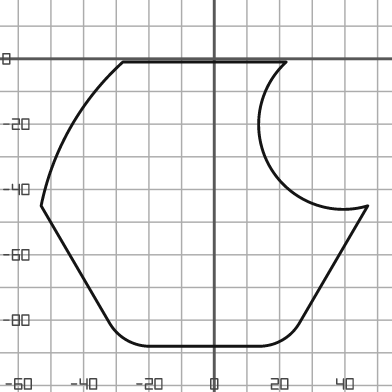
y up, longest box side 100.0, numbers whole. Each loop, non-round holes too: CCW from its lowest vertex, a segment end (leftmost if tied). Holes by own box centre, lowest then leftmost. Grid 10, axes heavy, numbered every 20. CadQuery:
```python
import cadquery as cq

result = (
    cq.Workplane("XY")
    .moveTo(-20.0, -88.0)
    .lineTo(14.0, -88.0)
    .threePointArc((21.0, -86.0), (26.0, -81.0))
    .lineTo(47.0, -45.0)
    .threePointArc((17.0, -33.0), (22.0, -1.0))
    .lineTo(-28.0, -1.0)
    .threePointArc((-44.0, -21.0), (-53.0, -45.0))
    .lineTo(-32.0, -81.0)
    .threePointArc((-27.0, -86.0), (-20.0, -88.0))
    .close()
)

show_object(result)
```